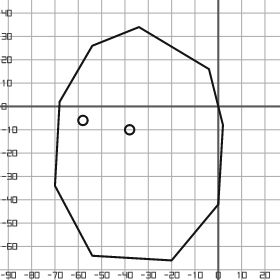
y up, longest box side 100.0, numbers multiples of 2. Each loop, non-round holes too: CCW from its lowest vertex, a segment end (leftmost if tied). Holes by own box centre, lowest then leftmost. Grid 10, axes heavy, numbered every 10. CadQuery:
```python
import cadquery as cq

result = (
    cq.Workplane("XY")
    .moveTo(-20.0, -66.0)
    .lineTo(0.0, -42.0)
    .lineTo(2.0, -8.0)
    .lineTo(-4.0, 16.0)
    .lineTo(-34.0, 34.0)
    .lineTo(-54.0, 26.0)
    .lineTo(-68.0, 2.0)
    .lineTo(-70.0, -34.0)
    .lineTo(-54.0, -64.0)
    .close()
    .moveTo(-38.0, -10.0)
    .circle(2.0)
    .moveTo(-58.0, -6.0)
    .circle(2.0)
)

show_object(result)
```